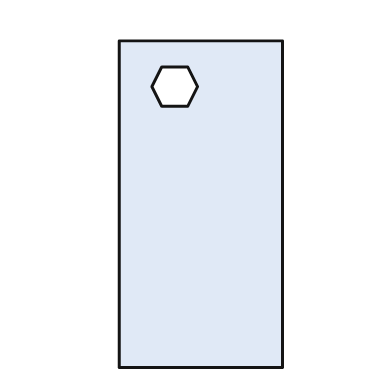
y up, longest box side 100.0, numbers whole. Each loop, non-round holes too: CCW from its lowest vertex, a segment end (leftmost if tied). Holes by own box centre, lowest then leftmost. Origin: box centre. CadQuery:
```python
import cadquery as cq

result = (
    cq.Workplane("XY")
    .moveTo(-25.0, -50.0)
    .lineTo(25.0, -50.0)
    .lineTo(25.0, 50.0)
    .lineTo(-25.0, 50.0)
    .close()
    .moveTo(-12.0, 30.0)
    .lineTo(-4.0, 30.0)
    .lineTo(-1.0, 36.0)
    .lineTo(-4.0, 42.0)
    .lineTo(-12.0, 42.0)
    .lineTo(-15.0, 36.0)
    .close()
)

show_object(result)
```